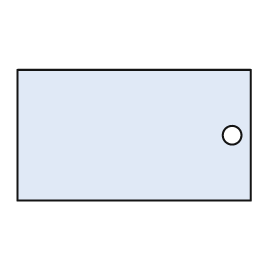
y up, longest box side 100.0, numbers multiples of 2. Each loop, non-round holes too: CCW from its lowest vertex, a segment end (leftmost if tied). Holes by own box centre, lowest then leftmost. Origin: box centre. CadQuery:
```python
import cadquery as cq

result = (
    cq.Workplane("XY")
    .moveTo(-50.0, -28.0)
    .lineTo(50.0, -28.0)
    .lineTo(50.0, 28.0)
    .lineTo(-50.0, 28.0)
    .close()
    .moveTo(42.0, 0.0)
    .circle(4.0)
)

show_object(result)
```